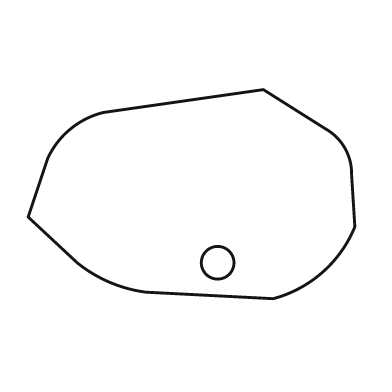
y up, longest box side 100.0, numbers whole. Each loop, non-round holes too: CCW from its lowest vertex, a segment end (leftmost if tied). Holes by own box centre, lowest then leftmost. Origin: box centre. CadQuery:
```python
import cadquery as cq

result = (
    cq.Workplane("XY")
    .moveTo(25.0, -32.0)
    .threePointArc((40.0, -24.0), (50.0, -10.0))
    .lineTo(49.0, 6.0)
    .threePointArc((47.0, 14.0), (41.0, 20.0))
    .lineTo(22.0, 32.0)
    .lineTo(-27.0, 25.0)
    .threePointArc((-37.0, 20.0), (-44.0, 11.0))
    .lineTo(-50.0, -7.0)
    .lineTo(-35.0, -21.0)
    .threePointArc((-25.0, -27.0), (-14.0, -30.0))
    .close()
    .moveTo(8.0, -21.0)
    .circle(5.0)
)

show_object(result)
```